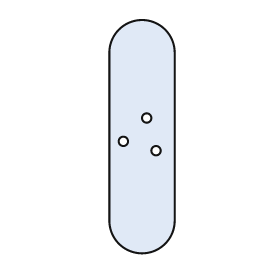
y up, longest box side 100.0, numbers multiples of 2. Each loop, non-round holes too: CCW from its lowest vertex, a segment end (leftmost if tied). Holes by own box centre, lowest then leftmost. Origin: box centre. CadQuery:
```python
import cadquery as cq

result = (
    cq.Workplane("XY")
    .moveTo(-14.0, -36.0)
    .threePointArc((0.0, -50.0), (14.0, -36.0))
    .lineTo(14.0, 36.0)
    .threePointArc((0.0, 50.0), (-14.0, 36.0))
    .close()
    .moveTo(6.0, -6.0)
    .circle(2.0)
    .moveTo(-8.0, -2.0)
    .circle(2.0)
    .moveTo(2.0, 8.0)
    .circle(2.0)
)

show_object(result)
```